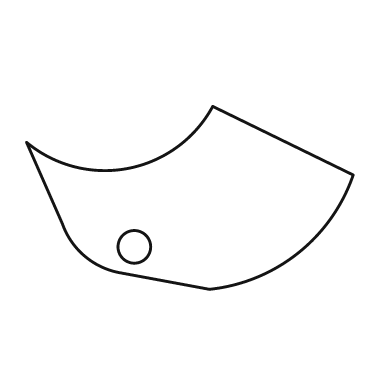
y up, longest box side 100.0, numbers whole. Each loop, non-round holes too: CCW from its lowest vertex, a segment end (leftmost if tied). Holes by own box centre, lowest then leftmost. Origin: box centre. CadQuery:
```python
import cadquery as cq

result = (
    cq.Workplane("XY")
    .moveTo(6.0, -28.0)
    .threePointArc((33.0, -17.0), (50.0, 7.0))
    .lineTo(7.0, 28.0)
    .threePointArc((-19.0, 9.0), (-50.0, 17.0))
    .lineTo(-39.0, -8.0)
    .threePointArc((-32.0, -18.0), (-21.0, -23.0))
    .close()
    .moveTo(-17.0, -15.0)
    .circle(5.0)
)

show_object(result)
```